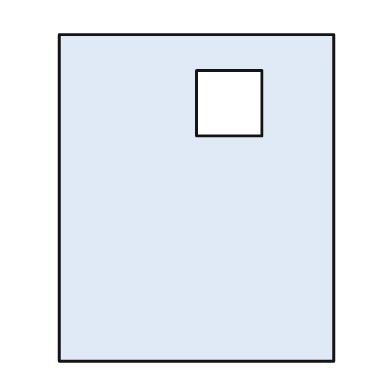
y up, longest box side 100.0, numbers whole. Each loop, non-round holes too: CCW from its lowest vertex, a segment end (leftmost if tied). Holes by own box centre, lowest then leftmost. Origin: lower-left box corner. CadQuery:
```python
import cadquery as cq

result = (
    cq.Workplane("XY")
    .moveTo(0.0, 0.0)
    .lineTo(84.0, 0.0)
    .lineTo(84.0, 100.0)
    .lineTo(0.0, 100.0)
    .close()
    .moveTo(42.0, 69.0)
    .lineTo(62.0, 69.0)
    .lineTo(62.0, 89.0)
    .lineTo(42.0, 89.0)
    .close()
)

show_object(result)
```